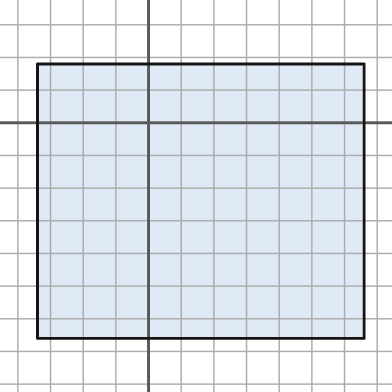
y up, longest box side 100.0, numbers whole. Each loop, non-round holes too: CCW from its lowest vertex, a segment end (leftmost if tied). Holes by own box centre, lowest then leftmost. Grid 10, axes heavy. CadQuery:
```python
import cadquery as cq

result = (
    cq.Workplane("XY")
    .moveTo(-34.0, -66.0)
    .lineTo(66.0, -66.0)
    .lineTo(66.0, 18.0)
    .lineTo(-34.0, 18.0)
    .close()
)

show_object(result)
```